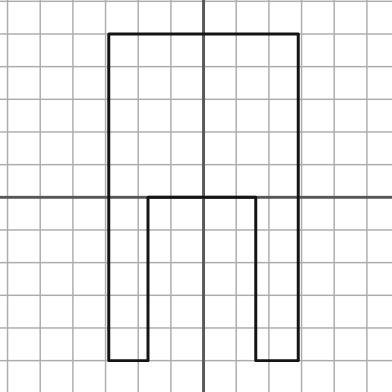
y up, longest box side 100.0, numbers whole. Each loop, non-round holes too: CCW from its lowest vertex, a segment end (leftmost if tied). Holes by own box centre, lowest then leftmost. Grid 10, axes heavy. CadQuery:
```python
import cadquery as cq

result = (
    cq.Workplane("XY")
    .moveTo(-29.0, -50.0)
    .lineTo(-17.0, -50.0)
    .lineTo(-17.0, 0.0)
    .lineTo(16.0, 0.0)
    .lineTo(16.0, -50.0)
    .lineTo(29.0, -50.0)
    .lineTo(29.0, 50.0)
    .lineTo(-29.0, 50.0)
    .close()
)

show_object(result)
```